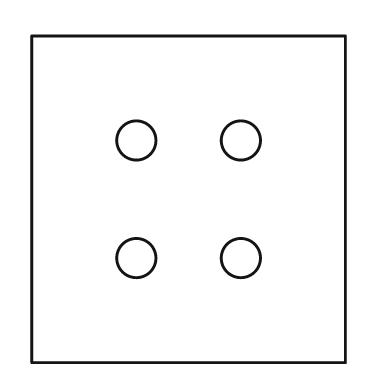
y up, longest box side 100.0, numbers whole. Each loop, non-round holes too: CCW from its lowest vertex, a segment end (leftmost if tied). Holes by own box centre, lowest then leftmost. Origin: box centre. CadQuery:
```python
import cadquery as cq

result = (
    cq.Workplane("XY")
    .moveTo(-48.0, -50.0)
    .lineTo(48.0, -50.0)
    .lineTo(48.0, 50.0)
    .lineTo(-48.0, 50.0)
    .close()
    .moveTo(-16.0, -18.0)
    .circle(6.0)
    .moveTo(16.0, -18.0)
    .circle(6.0)
    .moveTo(-16.0, 18.0)
    .circle(6.0)
    .moveTo(16.0, 18.0)
    .circle(6.0)
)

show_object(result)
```